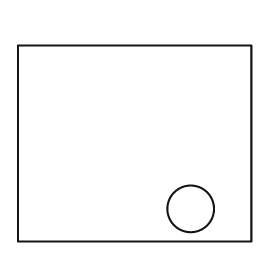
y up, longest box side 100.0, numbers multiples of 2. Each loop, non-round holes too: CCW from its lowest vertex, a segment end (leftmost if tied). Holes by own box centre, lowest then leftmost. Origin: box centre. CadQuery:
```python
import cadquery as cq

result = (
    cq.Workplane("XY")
    .moveTo(-50.0, -42.0)
    .lineTo(50.0, -42.0)
    .lineTo(50.0, 42.0)
    .lineTo(-50.0, 42.0)
    .close()
    .moveTo(24.0, -28.0)
    .circle(10.0)
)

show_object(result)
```